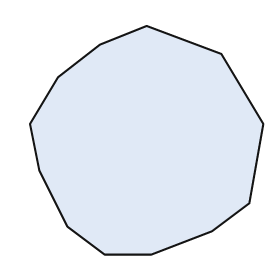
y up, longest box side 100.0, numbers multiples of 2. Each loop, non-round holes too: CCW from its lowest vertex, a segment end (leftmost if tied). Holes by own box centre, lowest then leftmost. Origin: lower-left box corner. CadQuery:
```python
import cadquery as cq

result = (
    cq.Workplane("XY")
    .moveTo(32.0, 0.0)
    .lineTo(52.0, 0.0)
    .lineTo(78.0, 10.0)
    .lineTo(94.0, 22.0)
    .lineTo(100.0, 56.0)
    .lineTo(82.0, 86.0)
    .lineTo(50.0, 98.0)
    .lineTo(30.0, 90.0)
    .lineTo(12.0, 76.0)
    .lineTo(0.0, 56.0)
    .lineTo(4.0, 36.0)
    .lineTo(16.0, 12.0)
    .close()
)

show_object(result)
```